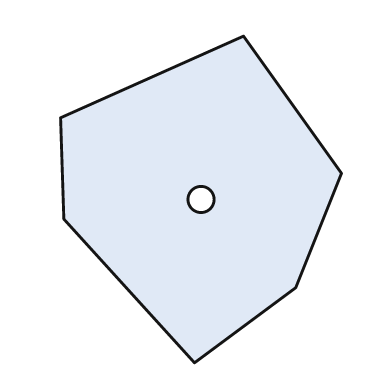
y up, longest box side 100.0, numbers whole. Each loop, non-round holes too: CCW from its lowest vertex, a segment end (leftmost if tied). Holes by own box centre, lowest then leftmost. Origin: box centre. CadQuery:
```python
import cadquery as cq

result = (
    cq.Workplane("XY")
    .moveTo(-2.0, -50.0)
    .lineTo(29.0, -27.0)
    .lineTo(43.0, 8.0)
    .lineTo(13.0, 50.0)
    .lineTo(-43.0, 25.0)
    .lineTo(-42.0, -6.0)
    .close()
    .moveTo(0.0, 0.0)
    .circle(4.0)
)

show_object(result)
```